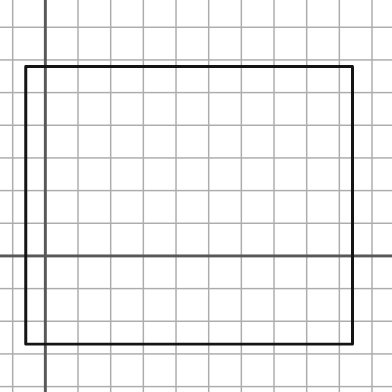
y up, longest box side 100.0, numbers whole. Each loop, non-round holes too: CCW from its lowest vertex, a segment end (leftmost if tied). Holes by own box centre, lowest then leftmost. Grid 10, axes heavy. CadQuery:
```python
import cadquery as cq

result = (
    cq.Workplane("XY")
    .moveTo(-6.0, -27.0)
    .lineTo(94.0, -27.0)
    .lineTo(94.0, 58.0)
    .lineTo(-6.0, 58.0)
    .close()
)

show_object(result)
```